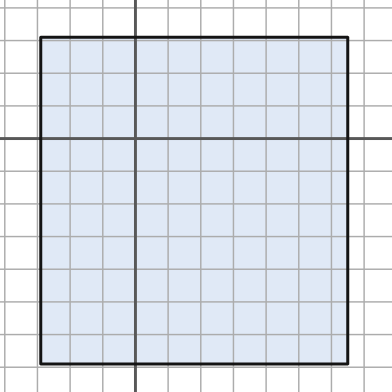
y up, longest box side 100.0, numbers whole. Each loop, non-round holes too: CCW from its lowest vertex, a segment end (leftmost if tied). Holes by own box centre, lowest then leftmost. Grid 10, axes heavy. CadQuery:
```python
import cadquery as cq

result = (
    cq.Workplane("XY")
    .moveTo(-29.0, -69.0)
    .lineTo(65.0, -69.0)
    .lineTo(65.0, 31.0)
    .lineTo(-29.0, 31.0)
    .close()
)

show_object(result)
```